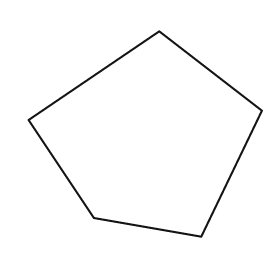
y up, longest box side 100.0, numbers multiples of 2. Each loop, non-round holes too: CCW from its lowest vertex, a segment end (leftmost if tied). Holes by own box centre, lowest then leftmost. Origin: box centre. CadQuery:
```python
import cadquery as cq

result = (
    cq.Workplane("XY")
    .moveTo(24.0, -44.0)
    .lineTo(50.0, 10.0)
    .lineTo(6.0, 44.0)
    .lineTo(-50.0, 6.0)
    .lineTo(-22.0, -36.0)
    .close()
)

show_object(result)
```